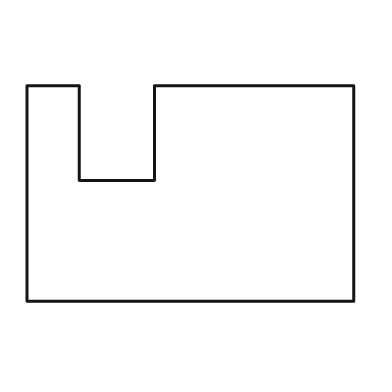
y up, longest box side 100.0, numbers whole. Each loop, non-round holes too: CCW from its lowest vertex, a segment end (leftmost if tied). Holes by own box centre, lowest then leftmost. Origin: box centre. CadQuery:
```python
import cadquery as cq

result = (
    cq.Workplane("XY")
    .moveTo(-50.0, -33.0)
    .lineTo(50.0, -33.0)
    .lineTo(50.0, 33.0)
    .lineTo(-11.0, 33.0)
    .lineTo(-11.0, 4.0)
    .lineTo(-34.0, 4.0)
    .lineTo(-34.0, 33.0)
    .lineTo(-50.0, 33.0)
    .close()
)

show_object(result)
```